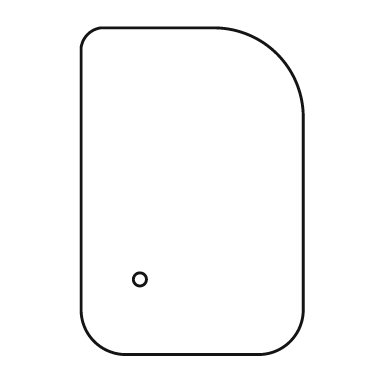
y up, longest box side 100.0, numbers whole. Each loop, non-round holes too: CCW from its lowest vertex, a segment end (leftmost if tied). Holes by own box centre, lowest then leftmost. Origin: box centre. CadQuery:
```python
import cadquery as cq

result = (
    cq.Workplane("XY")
    .moveTo(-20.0, -50.0)
    .lineTo(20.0, -50.0)
    .threePointArc((30.0, -46.0), (34.0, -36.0))
    .lineTo(34.0, 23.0)
    .threePointArc((26.0, 42.0), (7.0, 50.0))
    .lineTo(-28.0, 50.0)
    .threePointArc((-32.0, 48.0), (-34.0, 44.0))
    .lineTo(-34.0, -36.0)
    .threePointArc((-30.0, -46.0), (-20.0, -50.0))
    .close()
    .moveTo(-16.0, -27.0)
    .circle(2.0)
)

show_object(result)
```